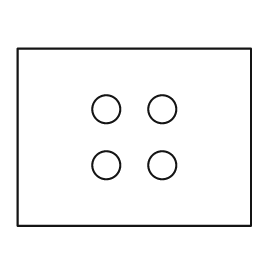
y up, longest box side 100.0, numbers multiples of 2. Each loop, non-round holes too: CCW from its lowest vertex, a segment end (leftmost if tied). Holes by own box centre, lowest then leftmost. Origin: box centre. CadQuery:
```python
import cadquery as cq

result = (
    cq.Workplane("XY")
    .moveTo(-50.0, -38.0)
    .lineTo(50.0, -38.0)
    .lineTo(50.0, 38.0)
    .lineTo(-50.0, 38.0)
    .close()
    .moveTo(-12.0, -12.0)
    .circle(6.0)
    .moveTo(12.0, -12.0)
    .circle(6.0)
    .moveTo(-12.0, 12.0)
    .circle(6.0)
    .moveTo(12.0, 12.0)
    .circle(6.0)
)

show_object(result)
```